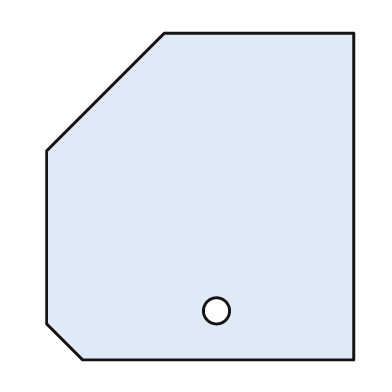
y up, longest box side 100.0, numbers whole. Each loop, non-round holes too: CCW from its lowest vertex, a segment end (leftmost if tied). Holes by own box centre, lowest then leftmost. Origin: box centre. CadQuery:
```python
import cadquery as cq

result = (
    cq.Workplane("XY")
    .moveTo(-36.0, -50.0)
    .lineTo(47.0, -50.0)
    .lineTo(47.0, 50.0)
    .lineTo(-11.0, 50.0)
    .lineTo(-47.0, 14.0)
    .lineTo(-47.0, -39.0)
    .close()
    .moveTo(5.0, -35.0)
    .circle(4.0)
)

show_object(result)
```